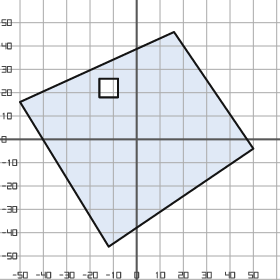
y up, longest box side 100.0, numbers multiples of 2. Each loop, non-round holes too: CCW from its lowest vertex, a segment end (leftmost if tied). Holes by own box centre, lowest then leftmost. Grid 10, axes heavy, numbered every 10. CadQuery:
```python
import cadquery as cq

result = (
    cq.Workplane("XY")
    .moveTo(-12.0, -46.0)
    .lineTo(50.0, -4.0)
    .lineTo(16.0, 46.0)
    .lineTo(-50.0, 16.0)
    .close()
    .moveTo(-16.0, 18.0)
    .lineTo(-8.0, 18.0)
    .lineTo(-8.0, 26.0)
    .lineTo(-16.0, 26.0)
    .close()
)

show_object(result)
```